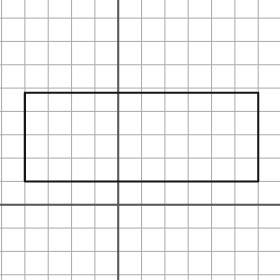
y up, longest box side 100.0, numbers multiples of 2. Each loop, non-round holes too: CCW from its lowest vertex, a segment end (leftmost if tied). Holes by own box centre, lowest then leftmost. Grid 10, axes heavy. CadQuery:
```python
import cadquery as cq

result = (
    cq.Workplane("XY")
    .moveTo(-40.0, 10.0)
    .lineTo(60.0, 10.0)
    .lineTo(60.0, 48.0)
    .lineTo(-40.0, 48.0)
    .close()
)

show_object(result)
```